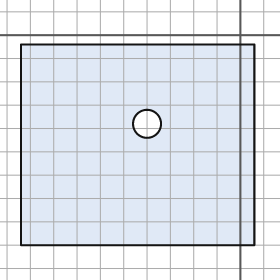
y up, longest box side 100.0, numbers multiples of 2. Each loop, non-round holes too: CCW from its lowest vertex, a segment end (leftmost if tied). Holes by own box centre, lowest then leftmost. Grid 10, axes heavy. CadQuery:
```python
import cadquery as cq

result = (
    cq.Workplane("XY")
    .moveTo(-94.0, -90.0)
    .lineTo(6.0, -90.0)
    .lineTo(6.0, -4.0)
    .lineTo(-94.0, -4.0)
    .close()
    .moveTo(-40.0, -38.0)
    .circle(6.0)
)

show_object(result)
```